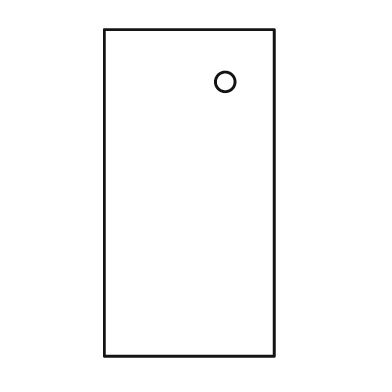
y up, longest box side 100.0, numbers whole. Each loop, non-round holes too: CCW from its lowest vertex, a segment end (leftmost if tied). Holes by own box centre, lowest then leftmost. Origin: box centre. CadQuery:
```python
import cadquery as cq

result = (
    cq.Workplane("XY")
    .moveTo(-26.0, -50.0)
    .lineTo(26.0, -50.0)
    .lineTo(26.0, 50.0)
    .lineTo(-26.0, 50.0)
    .close()
    .moveTo(11.0, 34.0)
    .circle(3.0)
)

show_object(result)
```